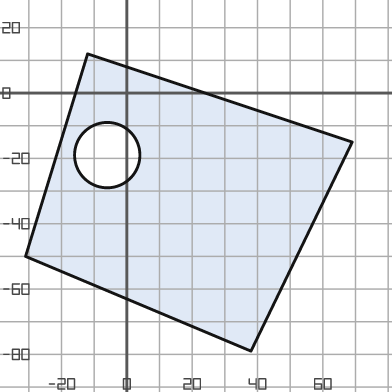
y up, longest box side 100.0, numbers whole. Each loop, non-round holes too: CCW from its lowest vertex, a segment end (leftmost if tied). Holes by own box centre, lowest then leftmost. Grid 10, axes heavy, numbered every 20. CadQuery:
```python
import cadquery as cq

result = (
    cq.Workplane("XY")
    .moveTo(38.0, -79.0)
    .lineTo(69.0, -15.0)
    .lineTo(-12.0, 12.0)
    .lineTo(-31.0, -50.0)
    .close()
    .moveTo(-6.0, -19.0)
    .circle(10.0)
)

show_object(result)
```